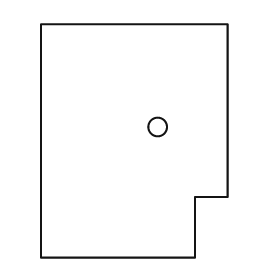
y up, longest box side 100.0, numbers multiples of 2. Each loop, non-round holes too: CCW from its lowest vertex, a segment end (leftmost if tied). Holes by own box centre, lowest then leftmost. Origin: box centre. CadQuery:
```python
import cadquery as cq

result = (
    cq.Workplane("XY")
    .moveTo(-40.0, -50.0)
    .lineTo(26.0, -50.0)
    .lineTo(26.0, -24.0)
    .lineTo(40.0, -24.0)
    .lineTo(40.0, 50.0)
    .lineTo(-40.0, 50.0)
    .close()
    .moveTo(10.0, 6.0)
    .circle(4.0)
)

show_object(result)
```